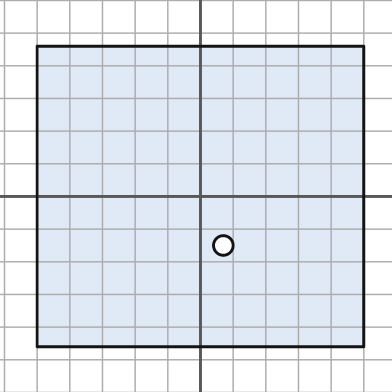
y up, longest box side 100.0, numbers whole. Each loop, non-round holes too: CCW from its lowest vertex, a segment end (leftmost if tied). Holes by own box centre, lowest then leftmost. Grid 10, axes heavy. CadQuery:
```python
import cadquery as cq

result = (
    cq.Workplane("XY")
    .moveTo(-50.0, -46.0)
    .lineTo(50.0, -46.0)
    .lineTo(50.0, 46.0)
    .lineTo(-50.0, 46.0)
    .close()
    .moveTo(7.0, -15.0)
    .circle(3.0)
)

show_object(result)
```